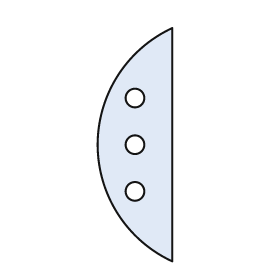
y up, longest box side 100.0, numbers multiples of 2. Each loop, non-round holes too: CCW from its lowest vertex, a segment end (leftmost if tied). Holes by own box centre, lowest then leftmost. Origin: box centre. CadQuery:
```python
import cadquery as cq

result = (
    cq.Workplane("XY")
    .moveTo(16.0, -50.0)
    .lineTo(16.0, 50.0)
    .threePointArc((-16.0, 0.0), (16.0, -50.0))
    .close()
    .moveTo(0.0, -20.0)
    .circle(4.0)
    .moveTo(0.0, 0.0)
    .circle(4.0)
    .moveTo(0.0, 20.0)
    .circle(4.0)
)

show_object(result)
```